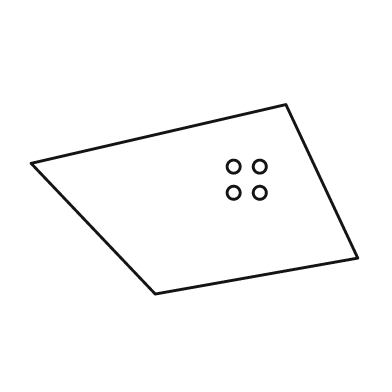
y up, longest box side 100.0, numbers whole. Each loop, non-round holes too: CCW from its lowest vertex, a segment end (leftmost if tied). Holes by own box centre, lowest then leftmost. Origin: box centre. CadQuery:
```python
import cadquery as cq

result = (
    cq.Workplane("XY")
    .moveTo(-12.0, -29.0)
    .lineTo(50.0, -18.0)
    .lineTo(28.0, 29.0)
    .lineTo(-50.0, 11.0)
    .close()
    .moveTo(12.0, 2.0)
    .circle(2.0)
    .moveTo(20.0, 2.0)
    .circle(2.0)
    .moveTo(12.0, 10.0)
    .circle(2.0)
    .moveTo(20.0, 10.0)
    .circle(2.0)
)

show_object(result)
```